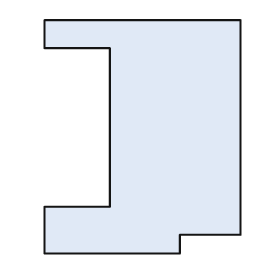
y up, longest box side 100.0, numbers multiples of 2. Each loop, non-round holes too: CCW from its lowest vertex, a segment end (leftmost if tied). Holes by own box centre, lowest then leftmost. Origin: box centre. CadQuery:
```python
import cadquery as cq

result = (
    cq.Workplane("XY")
    .moveTo(-42.0, -50.0)
    .lineTo(16.0, -50.0)
    .lineTo(16.0, -42.0)
    .lineTo(42.0, -42.0)
    .lineTo(42.0, 50.0)
    .lineTo(-42.0, 50.0)
    .lineTo(-42.0, 38.0)
    .lineTo(-14.0, 38.0)
    .lineTo(-14.0, -30.0)
    .lineTo(-42.0, -30.0)
    .close()
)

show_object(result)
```